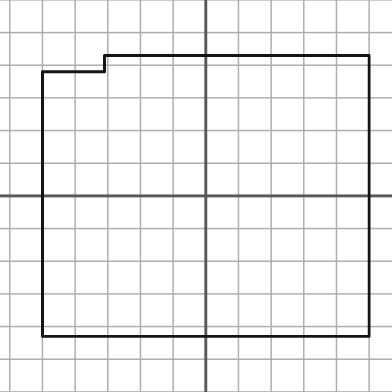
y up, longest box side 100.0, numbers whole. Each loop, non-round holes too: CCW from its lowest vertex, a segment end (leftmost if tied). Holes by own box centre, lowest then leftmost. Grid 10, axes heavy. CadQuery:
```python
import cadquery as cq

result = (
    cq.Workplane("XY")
    .moveTo(-50.0, -43.0)
    .lineTo(50.0, -43.0)
    .lineTo(50.0, 43.0)
    .lineTo(-31.0, 43.0)
    .lineTo(-31.0, 38.0)
    .lineTo(-50.0, 38.0)
    .close()
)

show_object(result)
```